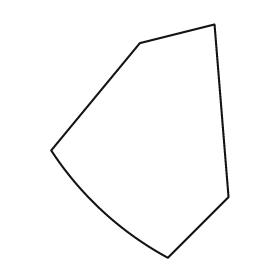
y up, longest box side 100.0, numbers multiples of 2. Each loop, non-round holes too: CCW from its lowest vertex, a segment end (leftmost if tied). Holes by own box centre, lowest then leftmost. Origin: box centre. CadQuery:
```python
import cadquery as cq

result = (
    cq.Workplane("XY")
    .moveTo(12.0, -50.0)
    .lineTo(38.0, -24.0)
    .lineTo(32.0, 50.0)
    .lineTo(0.0, 42.0)
    .lineTo(-38.0, -4.0)
    .threePointArc((-16.0, -30.0), (12.0, -50.0))
    .close()
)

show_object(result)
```